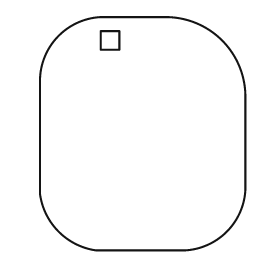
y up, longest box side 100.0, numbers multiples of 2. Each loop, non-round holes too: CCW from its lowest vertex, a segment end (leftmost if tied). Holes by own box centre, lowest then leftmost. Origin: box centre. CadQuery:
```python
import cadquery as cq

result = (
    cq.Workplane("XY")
    .moveTo(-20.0, -50.0)
    .lineTo(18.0, -50.0)
    .threePointArc((36.0, -42.0), (44.0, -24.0))
    .lineTo(44.0, 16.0)
    .threePointArc((34.0, 40.0), (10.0, 50.0))
    .lineTo(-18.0, 50.0)
    .threePointArc((-36.0, 42.0), (-44.0, 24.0))
    .lineTo(-44.0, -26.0)
    .threePointArc((-36.0, -42.0), (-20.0, -50.0))
    .close()
    .moveTo(-18.0, 36.0)
    .lineTo(-10.0, 36.0)
    .lineTo(-10.0, 44.0)
    .lineTo(-18.0, 44.0)
    .close()
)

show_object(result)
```